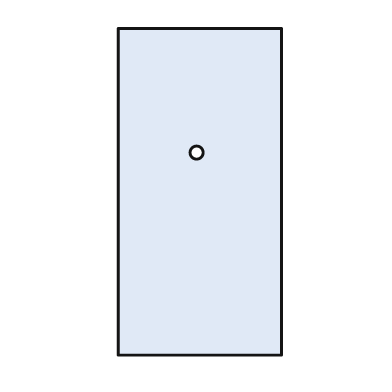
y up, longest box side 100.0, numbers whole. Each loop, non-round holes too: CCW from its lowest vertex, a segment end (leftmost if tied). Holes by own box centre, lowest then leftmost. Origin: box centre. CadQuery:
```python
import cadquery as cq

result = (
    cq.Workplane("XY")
    .moveTo(-25.0, -50.0)
    .lineTo(25.0, -50.0)
    .lineTo(25.0, 50.0)
    .lineTo(-25.0, 50.0)
    .close()
    .moveTo(-1.0, 12.0)
    .circle(2.0)
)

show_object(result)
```